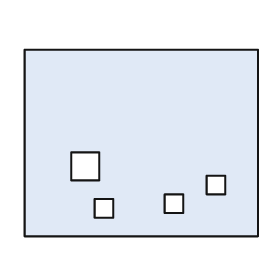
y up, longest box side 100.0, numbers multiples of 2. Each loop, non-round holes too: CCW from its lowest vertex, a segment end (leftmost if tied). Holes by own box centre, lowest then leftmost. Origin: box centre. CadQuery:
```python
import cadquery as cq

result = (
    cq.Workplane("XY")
    .moveTo(-50.0, -40.0)
    .lineTo(50.0, -40.0)
    .lineTo(50.0, 40.0)
    .lineTo(-50.0, 40.0)
    .close()
    .moveTo(-20.0, -32.0)
    .lineTo(-12.0, -32.0)
    .lineTo(-12.0, -24.0)
    .lineTo(-20.0, -24.0)
    .close()
    .moveTo(10.0, -30.0)
    .lineTo(18.0, -30.0)
    .lineTo(18.0, -22.0)
    .lineTo(10.0, -22.0)
    .close()
    .moveTo(28.0, -22.0)
    .lineTo(36.0, -22.0)
    .lineTo(36.0, -14.0)
    .lineTo(28.0, -14.0)
    .close()
    .moveTo(-30.0, -16.0)
    .lineTo(-18.0, -16.0)
    .lineTo(-18.0, -4.0)
    .lineTo(-30.0, -4.0)
    .close()
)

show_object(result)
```